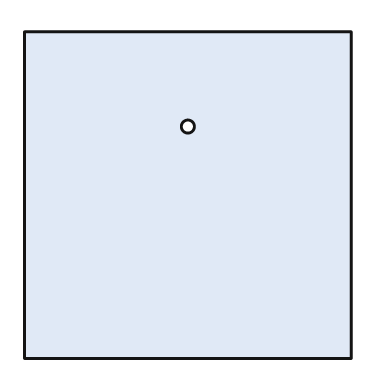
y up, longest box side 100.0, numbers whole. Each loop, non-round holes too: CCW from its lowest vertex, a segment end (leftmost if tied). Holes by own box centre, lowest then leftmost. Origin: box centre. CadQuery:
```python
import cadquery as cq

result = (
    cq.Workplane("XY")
    .moveTo(-50.0, -50.0)
    .lineTo(50.0, -50.0)
    .lineTo(50.0, 50.0)
    .lineTo(-50.0, 50.0)
    .close()
    .moveTo(0.0, 21.0)
    .circle(2.0)
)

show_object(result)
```